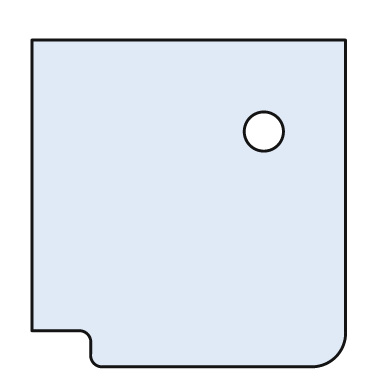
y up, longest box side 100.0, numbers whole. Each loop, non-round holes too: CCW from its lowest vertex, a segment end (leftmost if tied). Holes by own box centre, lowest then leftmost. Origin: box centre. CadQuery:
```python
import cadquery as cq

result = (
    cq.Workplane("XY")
    .moveTo(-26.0, -50.0)
    .lineTo(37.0, -50.0)
    .threePointArc((45.0, -47.0), (48.0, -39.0))
    .lineTo(48.0, 50.0)
    .lineTo(-48.0, 50.0)
    .lineTo(-48.0, -39.0)
    .lineTo(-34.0, -39.0)
    .threePointArc((-31.0, -40.0), (-30.0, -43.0))
    .lineTo(-30.0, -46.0)
    .threePointArc((-29.0, -49.0), (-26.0, -50.0))
    .close()
    .moveTo(23.0, 22.0)
    .circle(6.0)
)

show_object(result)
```